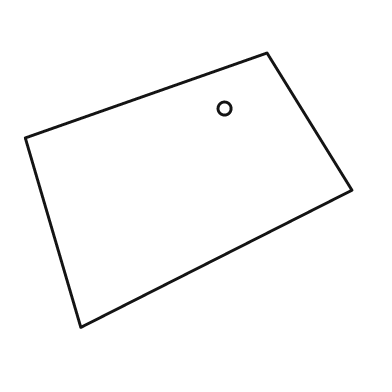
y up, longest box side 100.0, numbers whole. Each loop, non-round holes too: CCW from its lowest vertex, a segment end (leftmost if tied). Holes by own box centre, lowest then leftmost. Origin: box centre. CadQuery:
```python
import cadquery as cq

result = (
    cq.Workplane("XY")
    .moveTo(-33.0, -42.0)
    .lineTo(50.0, 0.0)
    .lineTo(24.0, 42.0)
    .lineTo(-50.0, 16.0)
    .close()
    .moveTo(11.0, 25.0)
    .circle(2.0)
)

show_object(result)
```